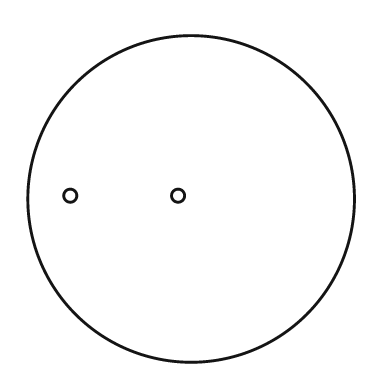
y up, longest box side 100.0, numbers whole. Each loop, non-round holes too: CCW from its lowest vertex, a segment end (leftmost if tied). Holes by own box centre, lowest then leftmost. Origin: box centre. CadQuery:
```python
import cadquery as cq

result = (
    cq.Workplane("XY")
    .moveTo(0.0, 0.0)
    .circle(50.0)
    .moveTo(-37.0, 1.0)
    .circle(2.0)
    .moveTo(-4.0, 1.0)
    .circle(2.0)
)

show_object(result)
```